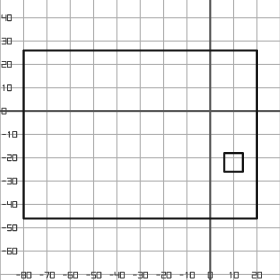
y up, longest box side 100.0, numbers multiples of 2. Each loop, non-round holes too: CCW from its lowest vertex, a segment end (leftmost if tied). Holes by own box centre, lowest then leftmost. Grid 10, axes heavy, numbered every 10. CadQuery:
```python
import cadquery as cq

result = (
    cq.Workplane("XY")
    .moveTo(-80.0, -46.0)
    .lineTo(20.0, -46.0)
    .lineTo(20.0, 26.0)
    .lineTo(-80.0, 26.0)
    .close()
    .moveTo(6.0, -26.0)
    .lineTo(14.0, -26.0)
    .lineTo(14.0, -18.0)
    .lineTo(6.0, -18.0)
    .close()
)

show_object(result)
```